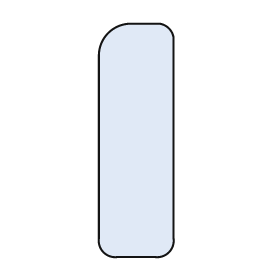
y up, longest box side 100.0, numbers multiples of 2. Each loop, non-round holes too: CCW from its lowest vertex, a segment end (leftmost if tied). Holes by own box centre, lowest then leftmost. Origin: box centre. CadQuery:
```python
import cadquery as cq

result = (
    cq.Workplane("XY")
    .moveTo(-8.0, -50.0)
    .lineTo(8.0, -50.0)
    .threePointArc((14.0, -48.0), (16.0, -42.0))
    .lineTo(16.0, 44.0)
    .threePointArc((14.0, 48.0), (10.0, 50.0))
    .lineTo(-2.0, 50.0)
    .threePointArc((-12.0, 46.0), (-16.0, 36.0))
    .lineTo(-16.0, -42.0)
    .threePointArc((-14.0, -48.0), (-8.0, -50.0))
    .close()
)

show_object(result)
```